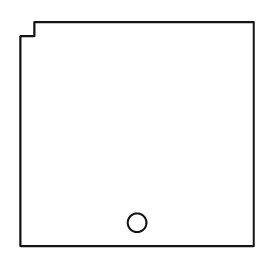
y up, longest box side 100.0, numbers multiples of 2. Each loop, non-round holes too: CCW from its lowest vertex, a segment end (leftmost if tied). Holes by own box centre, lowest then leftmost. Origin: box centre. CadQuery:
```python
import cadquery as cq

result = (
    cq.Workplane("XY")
    .moveTo(-50.0, -48.0)
    .lineTo(50.0, -48.0)
    .lineTo(50.0, 48.0)
    .lineTo(-44.0, 48.0)
    .lineTo(-44.0, 42.0)
    .lineTo(-50.0, 42.0)
    .close()
    .moveTo(0.0, -38.0)
    .circle(4.0)
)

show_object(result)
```